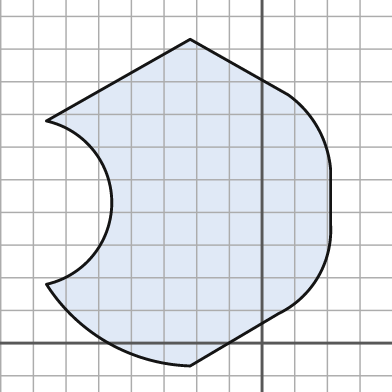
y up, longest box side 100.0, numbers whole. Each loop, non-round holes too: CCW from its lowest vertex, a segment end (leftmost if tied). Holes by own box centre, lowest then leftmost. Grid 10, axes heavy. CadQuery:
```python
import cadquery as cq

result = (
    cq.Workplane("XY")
    .moveTo(-22.0, -7.0)
    .lineTo(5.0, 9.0)
    .threePointArc((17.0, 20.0), (21.0, 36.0))
    .lineTo(21.0, 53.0)
    .threePointArc((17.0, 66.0), (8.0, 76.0))
    .lineTo(-22.0, 93.0)
    .lineTo(-66.0, 68.0)
    .threePointArc((-46.0, 43.0), (-66.0, 18.0))
    .threePointArc((-47.0, 0.0), (-22.0, -7.0))
    .close()
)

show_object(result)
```